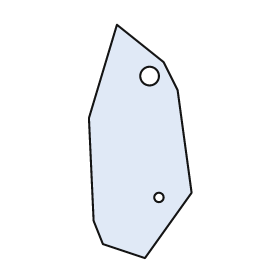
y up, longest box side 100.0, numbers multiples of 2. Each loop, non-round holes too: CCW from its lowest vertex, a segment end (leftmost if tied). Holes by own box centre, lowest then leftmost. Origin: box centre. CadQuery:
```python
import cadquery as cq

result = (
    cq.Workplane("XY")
    .moveTo(2.0, -50.0)
    .lineTo(22.0, -22.0)
    .lineTo(16.0, 22.0)
    .lineTo(10.0, 34.0)
    .lineTo(-10.0, 50.0)
    .lineTo(-22.0, 10.0)
    .lineTo(-20.0, -34.0)
    .lineTo(-16.0, -44.0)
    .close()
    .moveTo(8.0, -24.0)
    .circle(2.0)
    .moveTo(4.0, 28.0)
    .circle(4.0)
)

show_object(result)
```